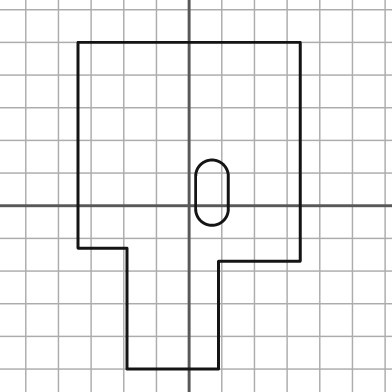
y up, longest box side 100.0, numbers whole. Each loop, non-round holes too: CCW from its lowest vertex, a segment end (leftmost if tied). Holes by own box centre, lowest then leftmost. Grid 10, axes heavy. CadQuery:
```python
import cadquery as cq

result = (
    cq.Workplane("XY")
    .moveTo(-19.0, -50.0)
    .lineTo(9.0, -50.0)
    .lineTo(9.0, -17.0)
    .lineTo(34.0, -17.0)
    .lineTo(34.0, 50.0)
    .lineTo(-34.0, 50.0)
    .lineTo(-34.0, -13.0)
    .lineTo(-19.0, -13.0)
    .close()
    .moveTo(2.0, -1.0)
    .threePointArc((7.0, -6.0), (12.0, -1.0))
    .lineTo(12.0, 9.0)
    .threePointArc((7.0, 14.0), (2.0, 9.0))
    .close()
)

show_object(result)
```